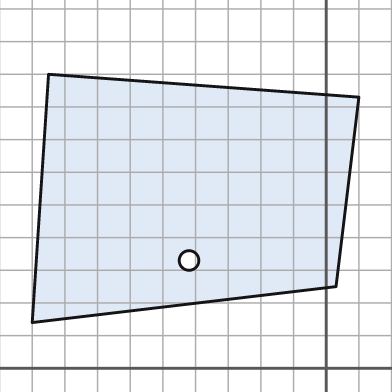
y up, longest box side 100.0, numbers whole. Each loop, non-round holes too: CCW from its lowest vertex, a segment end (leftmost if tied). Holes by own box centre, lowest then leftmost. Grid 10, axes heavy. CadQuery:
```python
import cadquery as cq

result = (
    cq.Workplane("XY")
    .moveTo(-90.0, 14.0)
    .lineTo(3.0, 25.0)
    .lineTo(10.0, 83.0)
    .lineTo(-85.0, 90.0)
    .close()
    .moveTo(-42.0, 33.0)
    .circle(3.0)
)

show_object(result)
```